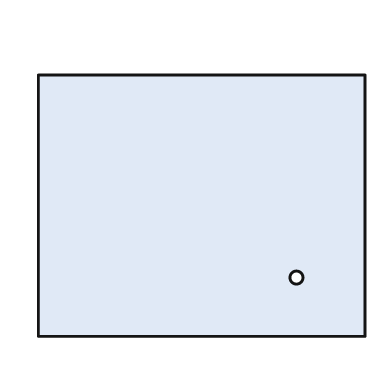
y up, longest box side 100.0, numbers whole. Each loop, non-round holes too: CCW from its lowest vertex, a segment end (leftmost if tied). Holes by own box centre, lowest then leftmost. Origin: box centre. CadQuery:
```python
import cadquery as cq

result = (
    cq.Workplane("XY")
    .moveTo(-50.0, -40.0)
    .lineTo(50.0, -40.0)
    .lineTo(50.0, 40.0)
    .lineTo(-50.0, 40.0)
    .close()
    .moveTo(29.0, -22.0)
    .circle(2.0)
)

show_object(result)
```